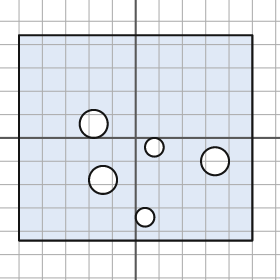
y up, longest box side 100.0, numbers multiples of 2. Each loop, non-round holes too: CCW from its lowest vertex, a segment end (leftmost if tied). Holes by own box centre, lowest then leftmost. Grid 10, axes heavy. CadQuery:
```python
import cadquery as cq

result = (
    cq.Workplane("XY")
    .moveTo(-50.0, -44.0)
    .lineTo(50.0, -44.0)
    .lineTo(50.0, 44.0)
    .lineTo(-50.0, 44.0)
    .close()
    .moveTo(4.0, -34.0)
    .circle(4.0)
    .moveTo(-14.0, -18.0)
    .circle(6.0)
    .moveTo(34.0, -10.0)
    .circle(6.0)
    .moveTo(8.0, -4.0)
    .circle(4.0)
    .moveTo(-18.0, 6.0)
    .circle(6.0)
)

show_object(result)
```